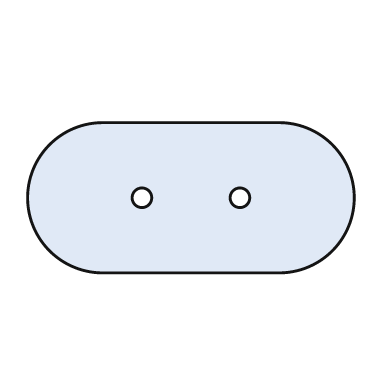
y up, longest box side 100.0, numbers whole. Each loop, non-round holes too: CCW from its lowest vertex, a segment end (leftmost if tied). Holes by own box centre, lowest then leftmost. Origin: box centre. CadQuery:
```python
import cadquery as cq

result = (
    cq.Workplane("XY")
    .moveTo(-27.0, -23.0)
    .lineTo(27.0, -23.0)
    .threePointArc((50.0, 0.0), (27.0, 23.0))
    .lineTo(-27.0, 23.0)
    .threePointArc((-50.0, 0.0), (-27.0, -23.0))
    .close()
    .moveTo(-15.0, 0.0)
    .circle(3.0)
    .moveTo(15.0, 0.0)
    .circle(3.0)
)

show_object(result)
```